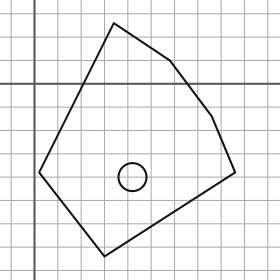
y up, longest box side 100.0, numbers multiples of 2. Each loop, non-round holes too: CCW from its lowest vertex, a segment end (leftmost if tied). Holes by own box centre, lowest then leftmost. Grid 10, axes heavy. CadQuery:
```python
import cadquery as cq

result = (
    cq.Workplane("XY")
    .moveTo(30.0, -74.0)
    .lineTo(86.0, -38.0)
    .lineTo(76.0, -14.0)
    .lineTo(58.0, 10.0)
    .lineTo(34.0, 26.0)
    .lineTo(2.0, -38.0)
    .close()
    .moveTo(42.0, -40.0)
    .circle(6.0)
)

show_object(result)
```